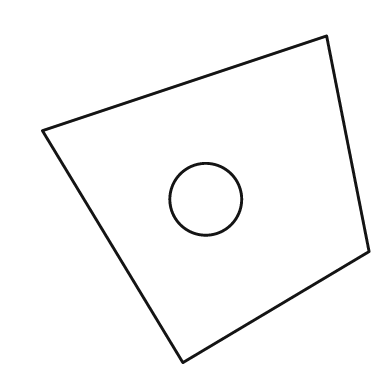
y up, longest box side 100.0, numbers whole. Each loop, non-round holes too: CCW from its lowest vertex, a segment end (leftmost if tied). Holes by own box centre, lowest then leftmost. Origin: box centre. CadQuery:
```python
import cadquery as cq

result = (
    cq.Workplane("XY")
    .moveTo(-7.0, -50.0)
    .lineTo(50.0, -16.0)
    .lineTo(37.0, 50.0)
    .lineTo(-50.0, 21.0)
    .close()
    .moveTo(0.0, 0.0)
    .circle(11.0)
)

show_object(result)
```